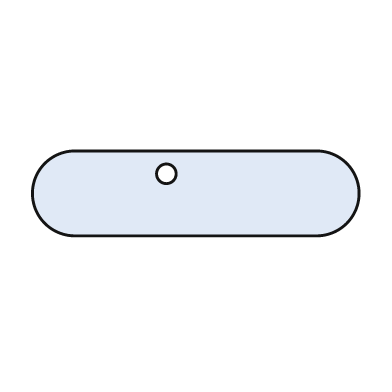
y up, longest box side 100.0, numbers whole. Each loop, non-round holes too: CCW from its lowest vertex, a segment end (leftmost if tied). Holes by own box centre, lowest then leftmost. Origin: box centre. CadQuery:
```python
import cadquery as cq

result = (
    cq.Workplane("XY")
    .moveTo(-37.0, -13.0)
    .lineTo(37.0, -13.0)
    .threePointArc((50.0, 0.0), (37.0, 13.0))
    .lineTo(-37.0, 13.0)
    .threePointArc((-50.0, 0.0), (-37.0, -13.0))
    .close()
    .moveTo(-9.0, 6.0)
    .circle(3.0)
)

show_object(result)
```